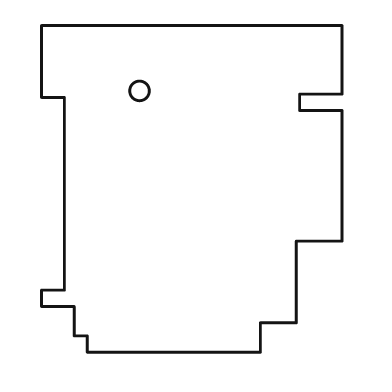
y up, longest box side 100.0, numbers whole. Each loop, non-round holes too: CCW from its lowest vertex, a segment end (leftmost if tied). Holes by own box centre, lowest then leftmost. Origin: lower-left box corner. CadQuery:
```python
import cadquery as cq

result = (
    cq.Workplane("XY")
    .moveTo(14.0, 0.0)
    .lineTo(67.0, 0.0)
    .lineTo(67.0, 9.0)
    .lineTo(78.0, 9.0)
    .lineTo(78.0, 34.0)
    .lineTo(92.0, 34.0)
    .lineTo(92.0, 74.0)
    .lineTo(79.0, 74.0)
    .lineTo(79.0, 79.0)
    .lineTo(92.0, 79.0)
    .lineTo(92.0, 100.0)
    .lineTo(0.0, 100.0)
    .lineTo(0.0, 78.0)
    .lineTo(7.0, 78.0)
    .lineTo(7.0, 19.0)
    .lineTo(0.0, 19.0)
    .lineTo(0.0, 14.0)
    .lineTo(10.0, 14.0)
    .lineTo(10.0, 5.0)
    .lineTo(14.0, 5.0)
    .close()
    .moveTo(30.0, 80.0)
    .circle(3.0)
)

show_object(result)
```